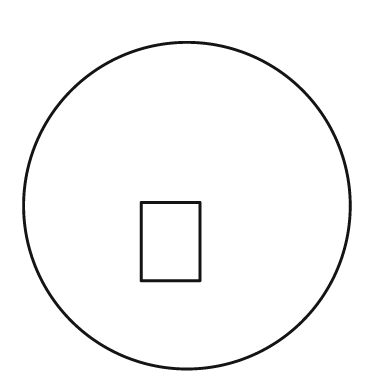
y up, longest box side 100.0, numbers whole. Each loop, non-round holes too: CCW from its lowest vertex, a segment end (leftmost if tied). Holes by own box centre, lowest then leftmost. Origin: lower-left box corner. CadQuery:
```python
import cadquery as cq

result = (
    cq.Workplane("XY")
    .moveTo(50.0, 50.0)
    .circle(50.0)
    .moveTo(36.0, 27.0)
    .lineTo(54.0, 27.0)
    .lineTo(54.0, 51.0)
    .lineTo(36.0, 51.0)
    .close()
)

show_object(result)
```